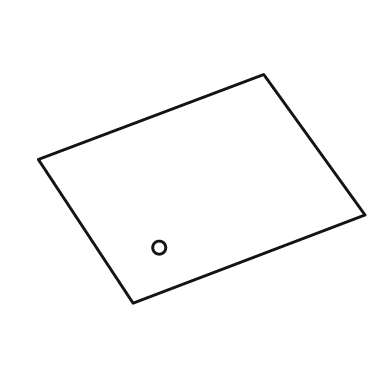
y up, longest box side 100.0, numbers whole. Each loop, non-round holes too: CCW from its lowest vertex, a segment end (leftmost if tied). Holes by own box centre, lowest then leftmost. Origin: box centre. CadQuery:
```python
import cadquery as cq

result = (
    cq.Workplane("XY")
    .moveTo(-21.0, -35.0)
    .lineTo(50.0, -8.0)
    .lineTo(19.0, 35.0)
    .lineTo(-50.0, 9.0)
    .close()
    .moveTo(-13.0, -18.0)
    .circle(2.0)
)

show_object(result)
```